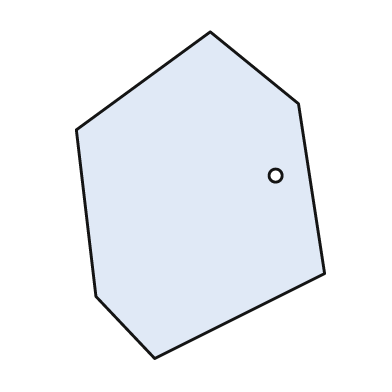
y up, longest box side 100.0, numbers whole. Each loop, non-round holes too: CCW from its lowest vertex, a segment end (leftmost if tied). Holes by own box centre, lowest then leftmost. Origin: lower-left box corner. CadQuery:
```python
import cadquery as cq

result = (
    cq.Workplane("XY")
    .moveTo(24.0, 0.0)
    .lineTo(76.0, 26.0)
    .lineTo(68.0, 78.0)
    .lineTo(41.0, 100.0)
    .lineTo(0.0, 70.0)
    .lineTo(6.0, 19.0)
    .close()
    .moveTo(61.0, 56.0)
    .circle(2.0)
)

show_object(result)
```